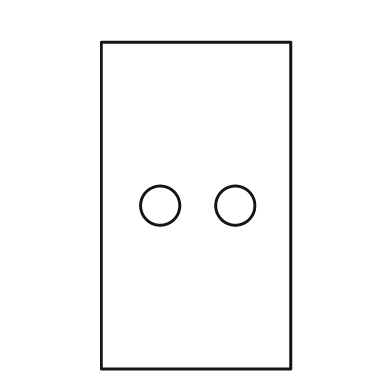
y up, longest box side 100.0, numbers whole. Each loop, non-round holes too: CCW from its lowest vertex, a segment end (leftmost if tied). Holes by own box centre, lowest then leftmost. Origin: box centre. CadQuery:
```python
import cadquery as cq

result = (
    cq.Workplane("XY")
    .moveTo(-29.0, -50.0)
    .lineTo(29.0, -50.0)
    .lineTo(29.0, 50.0)
    .lineTo(-29.0, 50.0)
    .close()
    .moveTo(-11.0, 0.0)
    .circle(6.0)
    .moveTo(12.0, 0.0)
    .circle(6.0)
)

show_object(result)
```